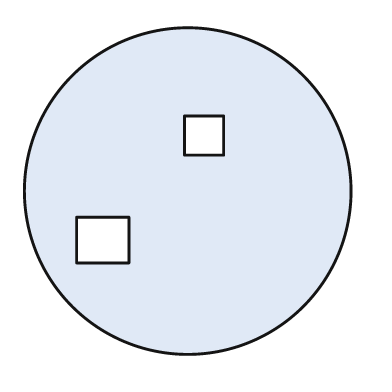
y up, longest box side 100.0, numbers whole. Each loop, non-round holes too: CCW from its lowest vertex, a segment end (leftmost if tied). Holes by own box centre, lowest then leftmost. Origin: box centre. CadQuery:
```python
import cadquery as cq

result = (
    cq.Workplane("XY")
    .moveTo(0.0, 0.0)
    .circle(50.0)
    .moveTo(-34.0, -22.0)
    .lineTo(-18.0, -22.0)
    .lineTo(-18.0, -8.0)
    .lineTo(-34.0, -8.0)
    .close()
    .moveTo(-1.0, 11.0)
    .lineTo(11.0, 11.0)
    .lineTo(11.0, 23.0)
    .lineTo(-1.0, 23.0)
    .close()
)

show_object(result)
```